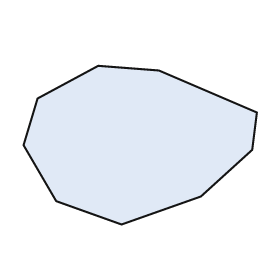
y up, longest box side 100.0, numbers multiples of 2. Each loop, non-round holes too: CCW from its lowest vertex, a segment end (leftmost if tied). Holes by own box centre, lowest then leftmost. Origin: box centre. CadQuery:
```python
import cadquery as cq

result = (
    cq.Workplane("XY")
    .moveTo(-8.0, -34.0)
    .lineTo(26.0, -22.0)
    .lineTo(48.0, -2.0)
    .lineTo(50.0, 14.0)
    .lineTo(8.0, 32.0)
    .lineTo(-18.0, 34.0)
    .lineTo(-44.0, 20.0)
    .lineTo(-50.0, 0.0)
    .lineTo(-36.0, -24.0)
    .close()
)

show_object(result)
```